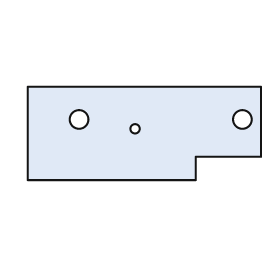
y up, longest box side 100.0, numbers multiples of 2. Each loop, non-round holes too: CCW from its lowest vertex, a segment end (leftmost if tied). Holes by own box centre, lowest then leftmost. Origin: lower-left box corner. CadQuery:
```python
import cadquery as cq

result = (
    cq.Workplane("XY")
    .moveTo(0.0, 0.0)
    .lineTo(72.0, 0.0)
    .lineTo(72.0, 10.0)
    .lineTo(100.0, 10.0)
    .lineTo(100.0, 40.0)
    .lineTo(0.0, 40.0)
    .close()
    .moveTo(46.0, 22.0)
    .circle(2.0)
    .moveTo(22.0, 26.0)
    .circle(4.0)
    .moveTo(92.0, 26.0)
    .circle(4.0)
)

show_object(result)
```